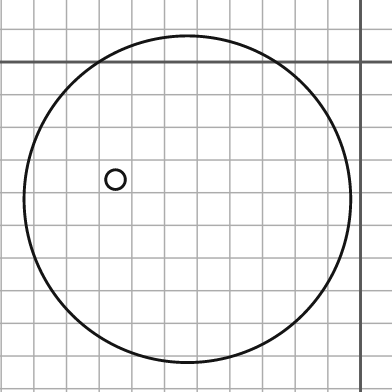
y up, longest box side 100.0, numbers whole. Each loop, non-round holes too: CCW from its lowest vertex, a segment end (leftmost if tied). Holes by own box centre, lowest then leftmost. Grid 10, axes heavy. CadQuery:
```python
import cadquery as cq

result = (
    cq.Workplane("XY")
    .moveTo(-53.0, -42.0)
    .circle(50.0)
    .moveTo(-75.0, -36.0)
    .circle(3.0)
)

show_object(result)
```